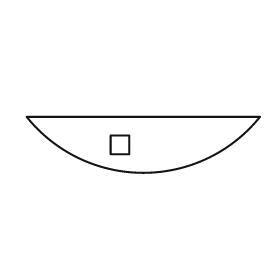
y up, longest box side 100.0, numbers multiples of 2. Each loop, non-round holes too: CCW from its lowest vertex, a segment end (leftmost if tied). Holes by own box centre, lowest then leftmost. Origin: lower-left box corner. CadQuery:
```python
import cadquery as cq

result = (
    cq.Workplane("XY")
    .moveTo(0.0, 24.0)
    .threePointArc((50.0, 0.0), (100.0, 24.0))
    .close()
    .moveTo(36.0, 8.0)
    .lineTo(44.0, 8.0)
    .lineTo(44.0, 16.0)
    .lineTo(36.0, 16.0)
    .close()
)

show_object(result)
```